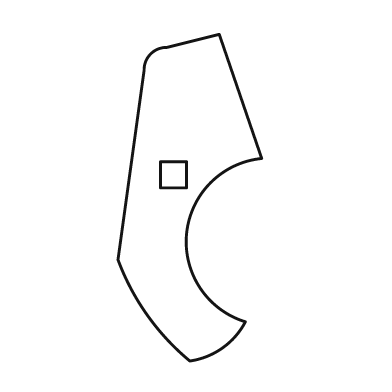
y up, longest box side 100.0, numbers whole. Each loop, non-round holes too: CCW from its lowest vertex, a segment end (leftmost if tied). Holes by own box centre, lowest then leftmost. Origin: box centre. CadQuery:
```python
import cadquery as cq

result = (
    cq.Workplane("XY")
    .moveTo(0.0, -50.0)
    .threePointArc((10.0, -46.0), (17.0, -38.0))
    .threePointArc((-1.0, -11.0), (22.0, 12.0))
    .lineTo(9.0, 50.0)
    .lineTo(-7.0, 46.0)
    .threePointArc((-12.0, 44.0), (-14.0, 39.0))
    .lineTo(-22.0, -19.0)
    .threePointArc((-13.0, -36.0), (0.0, -50.0))
    .close()
    .moveTo(-9.0, 3.0)
    .lineTo(-1.0, 3.0)
    .lineTo(-1.0, 11.0)
    .lineTo(-9.0, 11.0)
    .close()
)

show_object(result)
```